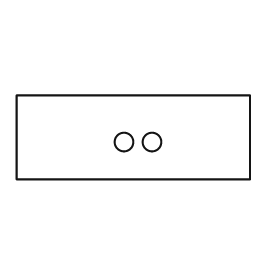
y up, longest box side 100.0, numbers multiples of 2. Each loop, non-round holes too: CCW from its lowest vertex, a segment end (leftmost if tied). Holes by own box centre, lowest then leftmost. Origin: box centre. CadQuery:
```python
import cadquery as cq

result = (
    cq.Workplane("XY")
    .moveTo(-50.0, -18.0)
    .lineTo(50.0, -18.0)
    .lineTo(50.0, 18.0)
    .lineTo(-50.0, 18.0)
    .close()
    .moveTo(-4.0, -2.0)
    .circle(4.0)
    .moveTo(8.0, -2.0)
    .circle(4.0)
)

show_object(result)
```